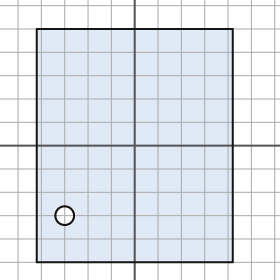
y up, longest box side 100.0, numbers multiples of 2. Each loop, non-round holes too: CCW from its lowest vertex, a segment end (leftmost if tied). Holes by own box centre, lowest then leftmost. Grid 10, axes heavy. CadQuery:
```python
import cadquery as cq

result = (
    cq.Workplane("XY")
    .moveTo(-42.0, -50.0)
    .lineTo(42.0, -50.0)
    .lineTo(42.0, 50.0)
    .lineTo(-42.0, 50.0)
    .close()
    .moveTo(-30.0, -30.0)
    .circle(4.0)
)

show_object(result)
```